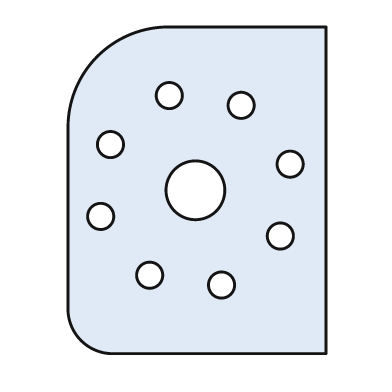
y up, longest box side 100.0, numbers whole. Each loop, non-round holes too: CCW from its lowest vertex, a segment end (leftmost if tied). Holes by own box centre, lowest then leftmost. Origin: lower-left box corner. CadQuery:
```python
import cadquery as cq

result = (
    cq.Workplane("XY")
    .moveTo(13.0, 0.0)
    .lineTo(79.0, 0.0)
    .lineTo(79.0, 100.0)
    .lineTo(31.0, 100.0)
    .threePointArc((9.0, 91.0), (0.0, 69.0))
    .lineTo(0.0, 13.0)
    .threePointArc((4.0, 4.0), (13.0, 0.0))
    .close()
    .moveTo(47.0, 21.0)
    .circle(4.0)
    .moveTo(25.0, 24.0)
    .circle(4.0)
    .moveTo(65.0, 36.0)
    .circle(4.0)
    .moveTo(10.0, 42.0)
    .circle(4.0)
    .moveTo(39.0, 50.0)
    .circle(9.0)
    .moveTo(68.0, 58.0)
    .circle(4.0)
    .moveTo(13.0, 64.0)
    .circle(4.0)
    .moveTo(53.0, 76.0)
    .circle(4.0)
    .moveTo(31.0, 79.0)
    .circle(4.0)
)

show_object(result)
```